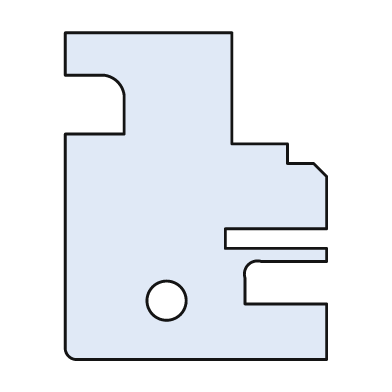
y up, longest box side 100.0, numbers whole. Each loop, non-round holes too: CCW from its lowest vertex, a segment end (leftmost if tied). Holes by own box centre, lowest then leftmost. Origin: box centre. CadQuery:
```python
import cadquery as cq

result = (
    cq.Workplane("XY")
    .moveTo(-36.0, -50.0)
    .lineTo(40.0, -50.0)
    .lineTo(40.0, -33.0)
    .lineTo(15.0, -33.0)
    .lineTo(15.0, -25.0)
    .threePointArc((16.0, -21.0), (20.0, -20.0))
    .lineTo(40.0, -20.0)
    .lineTo(40.0, -16.0)
    .lineTo(9.0, -16.0)
    .lineTo(9.0, -10.0)
    .lineTo(40.0, -10.0)
    .lineTo(40.0, 6.0)
    .lineTo(36.0, 10.0)
    .lineTo(28.0, 10.0)
    .lineTo(28.0, 16.0)
    .lineTo(11.0, 16.0)
    .lineTo(11.0, 50.0)
    .lineTo(-40.0, 50.0)
    .lineTo(-40.0, 37.0)
    .lineTo(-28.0, 37.0)
    .threePointArc((-24.0, 35.0), (-22.0, 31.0))
    .lineTo(-22.0, 19.0)
    .lineTo(-40.0, 19.0)
    .lineTo(-40.0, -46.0)
    .threePointArc((-39.0, -49.0), (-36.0, -50.0))
    .close()
    .moveTo(-9.0, -32.0)
    .circle(6.0)
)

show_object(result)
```